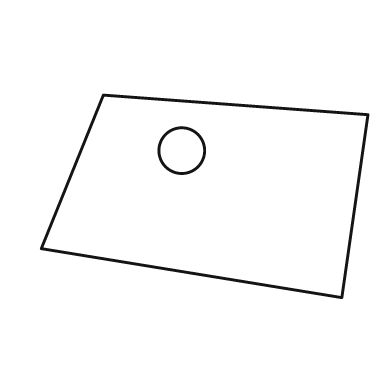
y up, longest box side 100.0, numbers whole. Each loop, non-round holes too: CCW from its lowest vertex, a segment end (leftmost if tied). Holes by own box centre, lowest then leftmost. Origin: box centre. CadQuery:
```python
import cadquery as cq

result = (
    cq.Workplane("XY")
    .moveTo(42.0, -31.0)
    .lineTo(50.0, 25.0)
    .lineTo(-31.0, 31.0)
    .lineTo(-50.0, -16.0)
    .close()
    .moveTo(-7.0, 14.0)
    .circle(7.0)
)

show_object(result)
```